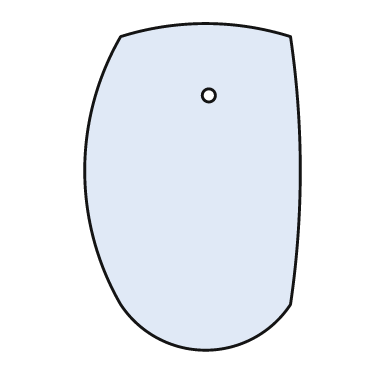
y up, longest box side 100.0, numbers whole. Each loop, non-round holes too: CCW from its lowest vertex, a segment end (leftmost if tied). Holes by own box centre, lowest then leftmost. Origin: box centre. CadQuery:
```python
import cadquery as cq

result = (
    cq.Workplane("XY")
    .moveTo(-22.0, -36.0)
    .threePointArc((4.0, -50.0), (30.0, -36.0))
    .threePointArc((33.0, 5.0), (30.0, 46.0))
    .threePointArc((4.0, 50.0), (-22.0, 46.0))
    .threePointArc((-33.0, 5.0), (-22.0, -36.0))
    .close()
    .moveTo(5.0, 28.0)
    .circle(2.0)
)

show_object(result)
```